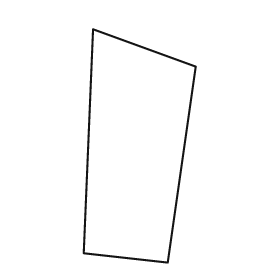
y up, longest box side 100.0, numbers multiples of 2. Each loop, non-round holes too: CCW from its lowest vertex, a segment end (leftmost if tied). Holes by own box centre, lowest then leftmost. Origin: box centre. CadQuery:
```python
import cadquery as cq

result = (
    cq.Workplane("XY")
    .moveTo(12.0, -50.0)
    .lineTo(24.0, 34.0)
    .lineTo(-20.0, 50.0)
    .lineTo(-24.0, -46.0)
    .close()
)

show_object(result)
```